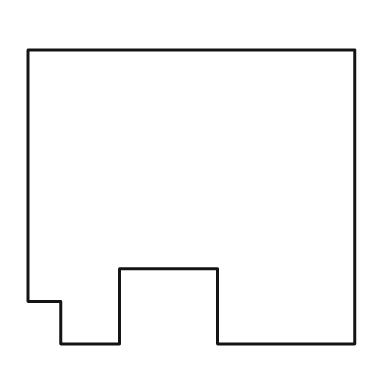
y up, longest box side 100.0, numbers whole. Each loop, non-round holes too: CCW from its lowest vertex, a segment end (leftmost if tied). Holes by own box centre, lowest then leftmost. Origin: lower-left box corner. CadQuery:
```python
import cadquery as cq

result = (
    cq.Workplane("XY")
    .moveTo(10.0, 0.0)
    .lineTo(28.0, 0.0)
    .lineTo(28.0, 23.0)
    .lineTo(58.0, 23.0)
    .lineTo(58.0, 0.0)
    .lineTo(100.0, 0.0)
    .lineTo(100.0, 90.0)
    .lineTo(0.0, 90.0)
    .lineTo(0.0, 13.0)
    .lineTo(10.0, 13.0)
    .close()
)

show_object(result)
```